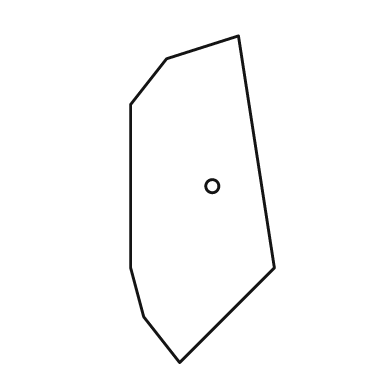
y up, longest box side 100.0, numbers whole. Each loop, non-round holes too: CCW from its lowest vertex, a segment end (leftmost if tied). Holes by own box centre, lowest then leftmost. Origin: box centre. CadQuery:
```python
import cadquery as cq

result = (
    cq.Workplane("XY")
    .moveTo(-7.0, -50.0)
    .lineTo(22.0, -21.0)
    .lineTo(11.0, 50.0)
    .lineTo(-11.0, 43.0)
    .lineTo(-22.0, 29.0)
    .lineTo(-22.0, -21.0)
    .lineTo(-18.0, -36.0)
    .close()
    .moveTo(3.0, 4.0)
    .circle(2.0)
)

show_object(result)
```